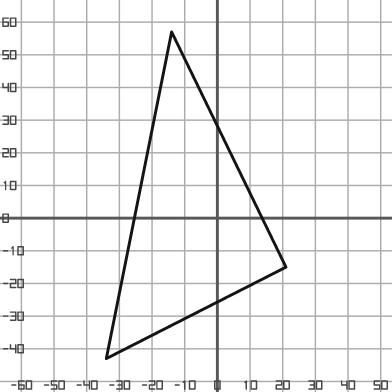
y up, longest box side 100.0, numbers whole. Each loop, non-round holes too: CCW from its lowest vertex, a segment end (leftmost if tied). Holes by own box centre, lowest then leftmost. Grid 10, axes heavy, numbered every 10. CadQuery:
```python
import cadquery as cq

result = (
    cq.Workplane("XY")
    .moveTo(-34.0, -43.0)
    .lineTo(21.0, -15.0)
    .lineTo(-14.0, 57.0)
    .close()
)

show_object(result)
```